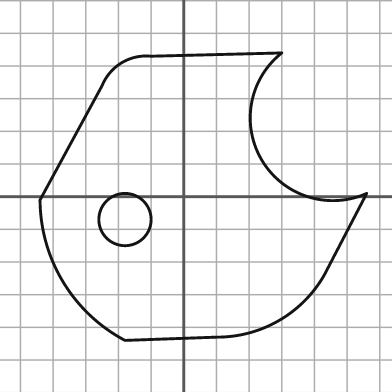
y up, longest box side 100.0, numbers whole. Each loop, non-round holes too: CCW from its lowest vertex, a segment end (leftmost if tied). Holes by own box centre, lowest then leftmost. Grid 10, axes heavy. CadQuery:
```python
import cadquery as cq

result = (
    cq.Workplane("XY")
    .moveTo(-18.0, -44.0)
    .lineTo(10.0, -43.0)
    .threePointArc((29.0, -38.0), (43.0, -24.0))
    .lineTo(56.0, 1.0)
    .threePointArc((24.0, 11.0), (30.0, 44.0))
    .lineTo(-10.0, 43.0)
    .threePointArc((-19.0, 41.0), (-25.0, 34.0))
    .lineTo(-44.0, -1.0)
    .threePointArc((-37.0, -26.0), (-18.0, -44.0))
    .close()
    .moveTo(-18.0, -7.0)
    .circle(8.0)
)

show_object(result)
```